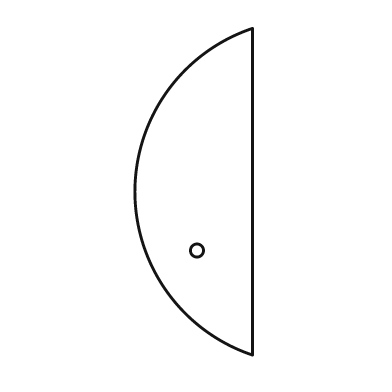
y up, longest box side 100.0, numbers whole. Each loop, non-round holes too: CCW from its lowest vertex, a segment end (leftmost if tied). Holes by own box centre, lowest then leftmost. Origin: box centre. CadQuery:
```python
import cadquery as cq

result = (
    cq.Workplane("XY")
    .moveTo(18.0, -50.0)
    .lineTo(18.0, 50.0)
    .threePointArc((-18.0, 0.0), (18.0, -50.0))
    .close()
    .moveTo(1.0, -18.0)
    .circle(2.0)
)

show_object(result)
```